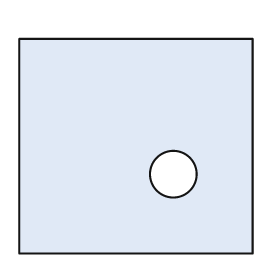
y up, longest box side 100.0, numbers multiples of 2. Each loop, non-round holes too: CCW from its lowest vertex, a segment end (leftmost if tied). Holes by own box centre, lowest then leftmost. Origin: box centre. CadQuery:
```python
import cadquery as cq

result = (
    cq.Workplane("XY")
    .moveTo(-50.0, -46.0)
    .lineTo(50.0, -46.0)
    .lineTo(50.0, 46.0)
    .lineTo(-50.0, 46.0)
    .close()
    .moveTo(16.0, -12.0)
    .circle(10.0)
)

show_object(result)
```